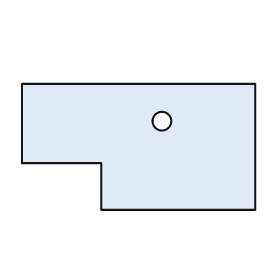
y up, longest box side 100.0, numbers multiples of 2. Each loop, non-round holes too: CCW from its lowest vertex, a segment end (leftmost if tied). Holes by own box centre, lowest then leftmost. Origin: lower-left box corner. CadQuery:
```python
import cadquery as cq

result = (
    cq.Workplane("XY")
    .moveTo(34.0, 0.0)
    .lineTo(100.0, 0.0)
    .lineTo(100.0, 54.0)
    .lineTo(0.0, 54.0)
    .lineTo(0.0, 20.0)
    .lineTo(34.0, 20.0)
    .close()
    .moveTo(60.0, 38.0)
    .circle(4.0)
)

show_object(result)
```